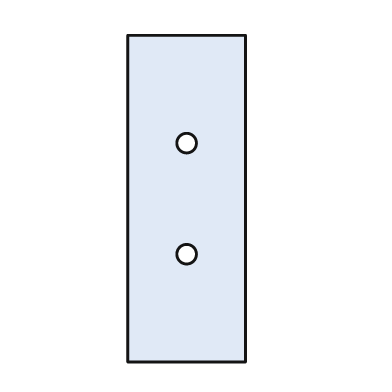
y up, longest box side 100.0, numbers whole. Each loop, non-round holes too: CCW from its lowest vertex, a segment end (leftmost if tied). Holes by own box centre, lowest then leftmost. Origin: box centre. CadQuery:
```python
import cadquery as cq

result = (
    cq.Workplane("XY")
    .moveTo(-18.0, -50.0)
    .lineTo(18.0, -50.0)
    .lineTo(18.0, 50.0)
    .lineTo(-18.0, 50.0)
    .close()
    .moveTo(0.0, -17.0)
    .circle(3.0)
    .moveTo(0.0, 17.0)
    .circle(3.0)
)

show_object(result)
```